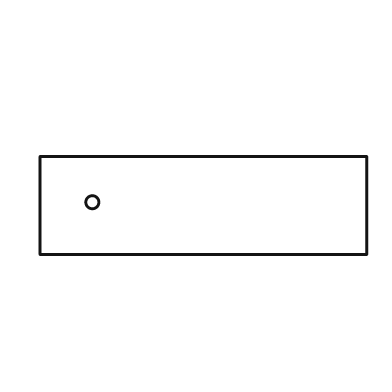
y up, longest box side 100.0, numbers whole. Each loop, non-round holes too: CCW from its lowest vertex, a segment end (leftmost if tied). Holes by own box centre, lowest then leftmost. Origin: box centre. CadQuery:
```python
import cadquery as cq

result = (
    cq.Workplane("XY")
    .moveTo(-50.0, -15.0)
    .lineTo(50.0, -15.0)
    .lineTo(50.0, 15.0)
    .lineTo(-50.0, 15.0)
    .close()
    .moveTo(-34.0, 1.0)
    .circle(2.0)
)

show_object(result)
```